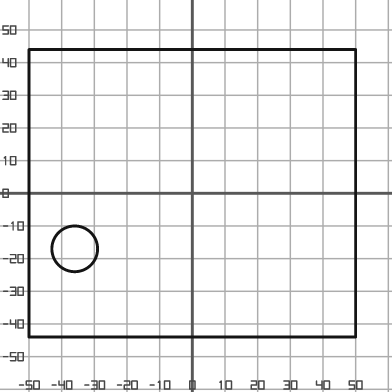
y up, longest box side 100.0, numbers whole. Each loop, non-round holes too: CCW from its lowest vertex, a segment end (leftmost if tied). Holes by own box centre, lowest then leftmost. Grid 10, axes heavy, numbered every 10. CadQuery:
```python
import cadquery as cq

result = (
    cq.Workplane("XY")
    .moveTo(-50.0, -44.0)
    .lineTo(50.0, -44.0)
    .lineTo(50.0, 44.0)
    .lineTo(-50.0, 44.0)
    .close()
    .moveTo(-36.0, -17.0)
    .circle(7.0)
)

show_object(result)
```